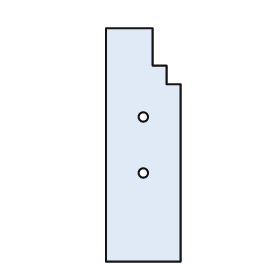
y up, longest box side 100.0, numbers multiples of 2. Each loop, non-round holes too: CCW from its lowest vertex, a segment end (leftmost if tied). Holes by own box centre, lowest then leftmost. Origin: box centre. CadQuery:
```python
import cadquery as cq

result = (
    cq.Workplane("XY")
    .moveTo(-16.0, -50.0)
    .lineTo(16.0, -50.0)
    .lineTo(16.0, 26.0)
    .lineTo(10.0, 26.0)
    .lineTo(10.0, 34.0)
    .lineTo(4.0, 34.0)
    .lineTo(4.0, 50.0)
    .lineTo(-16.0, 50.0)
    .close()
    .moveTo(0.0, -12.0)
    .circle(2.0)
    .moveTo(0.0, 12.0)
    .circle(2.0)
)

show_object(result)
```